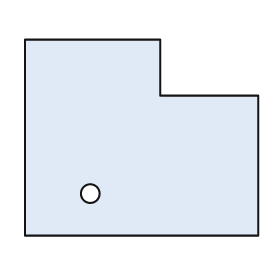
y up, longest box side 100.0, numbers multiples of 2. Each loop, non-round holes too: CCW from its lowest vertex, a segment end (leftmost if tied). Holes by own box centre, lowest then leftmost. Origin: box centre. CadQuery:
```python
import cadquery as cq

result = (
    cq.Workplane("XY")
    .moveTo(-50.0, -42.0)
    .lineTo(50.0, -42.0)
    .lineTo(50.0, 18.0)
    .lineTo(8.0, 18.0)
    .lineTo(8.0, 42.0)
    .lineTo(-50.0, 42.0)
    .close()
    .moveTo(-22.0, -24.0)
    .circle(4.0)
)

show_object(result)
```